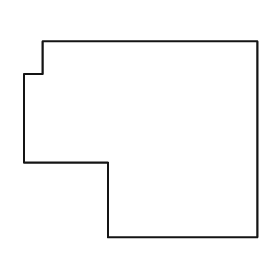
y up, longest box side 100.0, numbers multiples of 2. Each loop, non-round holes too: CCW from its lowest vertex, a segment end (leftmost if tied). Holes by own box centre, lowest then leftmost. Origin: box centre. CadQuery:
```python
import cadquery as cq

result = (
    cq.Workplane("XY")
    .moveTo(-14.0, -42.0)
    .lineTo(50.0, -42.0)
    .lineTo(50.0, 42.0)
    .lineTo(-42.0, 42.0)
    .lineTo(-42.0, 28.0)
    .lineTo(-50.0, 28.0)
    .lineTo(-50.0, -10.0)
    .lineTo(-14.0, -10.0)
    .close()
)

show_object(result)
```